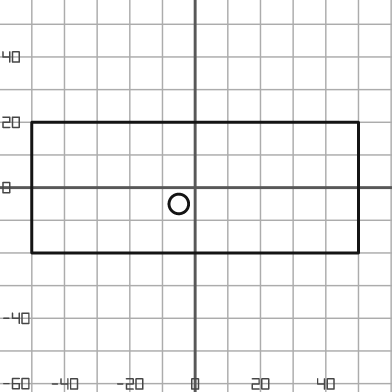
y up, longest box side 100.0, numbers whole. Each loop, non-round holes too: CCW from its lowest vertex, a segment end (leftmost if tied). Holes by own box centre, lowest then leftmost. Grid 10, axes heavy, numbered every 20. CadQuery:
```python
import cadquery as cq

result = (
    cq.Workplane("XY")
    .moveTo(-50.0, -20.0)
    .lineTo(50.0, -20.0)
    .lineTo(50.0, 20.0)
    .lineTo(-50.0, 20.0)
    .close()
    .moveTo(-5.0, -5.0)
    .circle(3.0)
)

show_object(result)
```